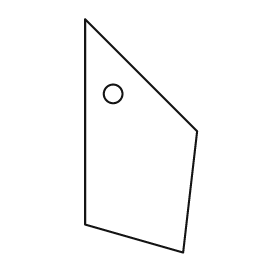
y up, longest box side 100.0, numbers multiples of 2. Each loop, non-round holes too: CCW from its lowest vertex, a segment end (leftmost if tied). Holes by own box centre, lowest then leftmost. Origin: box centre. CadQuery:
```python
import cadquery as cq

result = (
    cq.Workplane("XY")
    .moveTo(18.0, -50.0)
    .lineTo(24.0, 2.0)
    .lineTo(-24.0, 50.0)
    .lineTo(-24.0, -38.0)
    .close()
    .moveTo(-12.0, 18.0)
    .circle(4.0)
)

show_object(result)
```